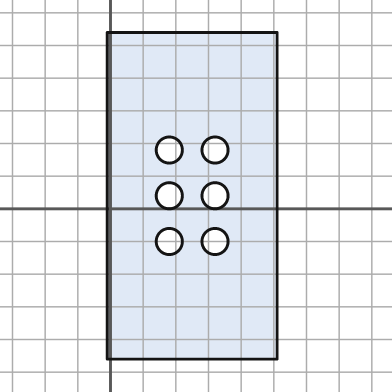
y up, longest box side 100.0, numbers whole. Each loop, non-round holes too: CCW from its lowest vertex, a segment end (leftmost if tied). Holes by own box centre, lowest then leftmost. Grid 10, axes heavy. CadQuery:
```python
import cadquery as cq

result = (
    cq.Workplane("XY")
    .moveTo(-1.0, -46.0)
    .lineTo(51.0, -46.0)
    .lineTo(51.0, 54.0)
    .lineTo(-1.0, 54.0)
    .close()
    .moveTo(18.0, -10.0)
    .circle(4.0)
    .moveTo(32.0, -10.0)
    .circle(4.0)
    .moveTo(18.0, 4.0)
    .circle(4.0)
    .moveTo(32.0, 4.0)
    .circle(4.0)
    .moveTo(18.0, 18.0)
    .circle(4.0)
    .moveTo(32.0, 18.0)
    .circle(4.0)
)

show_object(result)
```